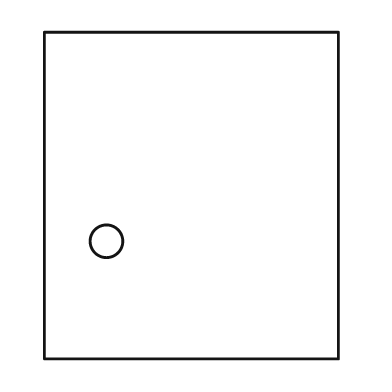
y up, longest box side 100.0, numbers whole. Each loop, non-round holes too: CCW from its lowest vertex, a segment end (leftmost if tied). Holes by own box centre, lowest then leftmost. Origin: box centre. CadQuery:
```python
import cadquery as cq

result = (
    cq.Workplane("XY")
    .moveTo(-45.0, -50.0)
    .lineTo(45.0, -50.0)
    .lineTo(45.0, 50.0)
    .lineTo(-45.0, 50.0)
    .close()
    .moveTo(-26.0, -14.0)
    .circle(5.0)
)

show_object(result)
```